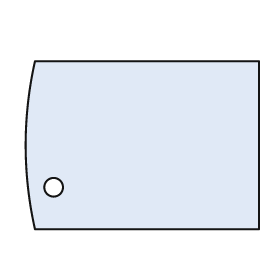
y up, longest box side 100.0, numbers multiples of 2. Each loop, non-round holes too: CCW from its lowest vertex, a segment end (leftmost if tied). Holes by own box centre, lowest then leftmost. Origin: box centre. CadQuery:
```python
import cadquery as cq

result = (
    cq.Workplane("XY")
    .moveTo(-46.0, -36.0)
    .lineTo(50.0, -36.0)
    .lineTo(50.0, 36.0)
    .lineTo(-46.0, 36.0)
    .threePointArc((-50.0, 0.0), (-46.0, -36.0))
    .close()
    .moveTo(-38.0, -18.0)
    .circle(4.0)
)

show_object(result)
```